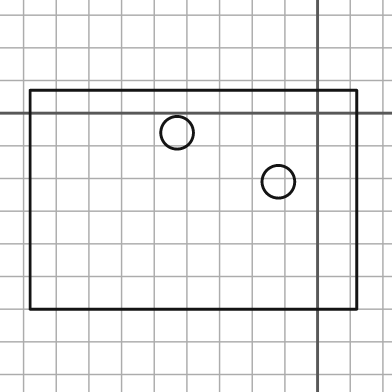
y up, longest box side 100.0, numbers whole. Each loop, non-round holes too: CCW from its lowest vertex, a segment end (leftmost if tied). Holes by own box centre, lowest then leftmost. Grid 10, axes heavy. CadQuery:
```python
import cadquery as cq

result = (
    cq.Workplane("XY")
    .moveTo(-88.0, -60.0)
    .lineTo(12.0, -60.0)
    .lineTo(12.0, 7.0)
    .lineTo(-88.0, 7.0)
    .close()
    .moveTo(-12.0, -21.0)
    .circle(5.0)
    .moveTo(-43.0, -6.0)
    .circle(5.0)
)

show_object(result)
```